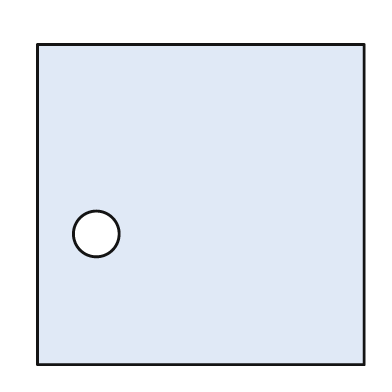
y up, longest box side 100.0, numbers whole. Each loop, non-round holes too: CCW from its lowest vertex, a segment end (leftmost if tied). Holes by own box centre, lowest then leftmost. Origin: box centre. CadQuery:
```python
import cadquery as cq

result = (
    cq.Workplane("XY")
    .moveTo(-50.0, -49.0)
    .lineTo(50.0, -49.0)
    .lineTo(50.0, 49.0)
    .lineTo(-50.0, 49.0)
    .close()
    .moveTo(-32.0, -9.0)
    .circle(7.0)
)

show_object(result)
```